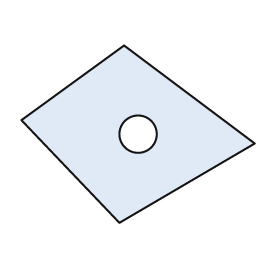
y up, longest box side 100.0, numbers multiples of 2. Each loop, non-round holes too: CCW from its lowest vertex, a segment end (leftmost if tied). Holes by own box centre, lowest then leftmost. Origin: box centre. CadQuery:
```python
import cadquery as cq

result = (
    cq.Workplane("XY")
    .moveTo(-8.0, -38.0)
    .lineTo(50.0, -4.0)
    .lineTo(-6.0, 38.0)
    .lineTo(-50.0, 6.0)
    .close()
    .moveTo(0.0, 0.0)
    .circle(8.0)
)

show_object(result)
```